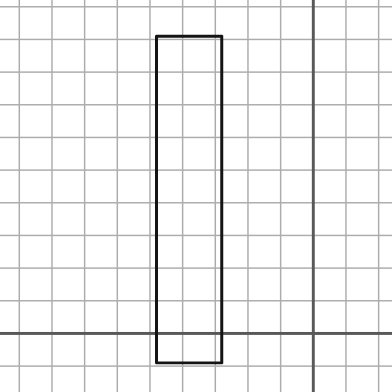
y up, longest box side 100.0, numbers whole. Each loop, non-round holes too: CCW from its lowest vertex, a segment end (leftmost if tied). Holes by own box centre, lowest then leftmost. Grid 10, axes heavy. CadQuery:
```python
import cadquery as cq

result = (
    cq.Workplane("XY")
    .moveTo(-48.0, -9.0)
    .lineTo(-28.0, -9.0)
    .lineTo(-28.0, 91.0)
    .lineTo(-48.0, 91.0)
    .close()
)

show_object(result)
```